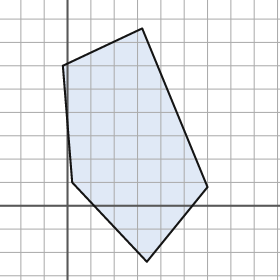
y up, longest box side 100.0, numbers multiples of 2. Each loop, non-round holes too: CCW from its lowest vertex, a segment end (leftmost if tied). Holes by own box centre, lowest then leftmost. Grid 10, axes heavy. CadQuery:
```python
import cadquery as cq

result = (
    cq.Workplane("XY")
    .moveTo(34.0, -24.0)
    .lineTo(60.0, 8.0)
    .lineTo(32.0, 76.0)
    .lineTo(-2.0, 60.0)
    .lineTo(2.0, 10.0)
    .close()
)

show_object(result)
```